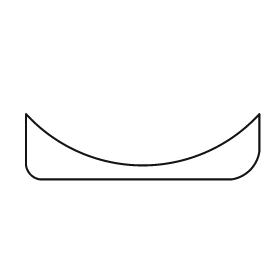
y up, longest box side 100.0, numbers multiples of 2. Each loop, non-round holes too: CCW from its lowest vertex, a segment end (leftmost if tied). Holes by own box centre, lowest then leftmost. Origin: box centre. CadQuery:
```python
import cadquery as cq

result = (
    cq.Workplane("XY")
    .moveTo(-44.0, -14.0)
    .lineTo(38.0, -14.0)
    .threePointArc((46.0, -10.0), (50.0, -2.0))
    .lineTo(50.0, 14.0)
    .threePointArc((0.0, -8.0), (-50.0, 14.0))
    .lineTo(-50.0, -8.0)
    .threePointArc((-48.0, -12.0), (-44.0, -14.0))
    .close()
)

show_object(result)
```